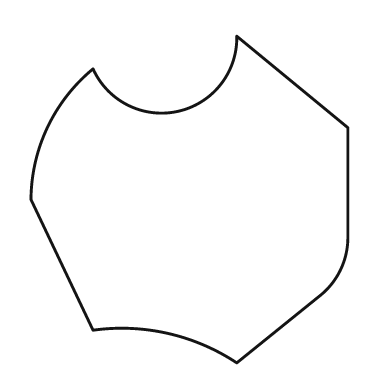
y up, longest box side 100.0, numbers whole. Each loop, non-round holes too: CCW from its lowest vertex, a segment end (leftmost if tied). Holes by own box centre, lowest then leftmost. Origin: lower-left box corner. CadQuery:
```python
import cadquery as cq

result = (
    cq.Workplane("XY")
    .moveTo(63.0, 0.0)
    .lineTo(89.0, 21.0)
    .threePointArc((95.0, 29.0), (97.0, 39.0))
    .lineTo(97.0, 72.0)
    .lineTo(63.0, 100.0)
    .threePointArc((45.0, 77.0), (19.0, 90.0))
    .threePointArc((5.0, 72.0), (0.0, 50.0))
    .lineTo(19.0, 10.0)
    .threePointArc((42.0, 9.0), (63.0, 0.0))
    .close()
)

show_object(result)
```